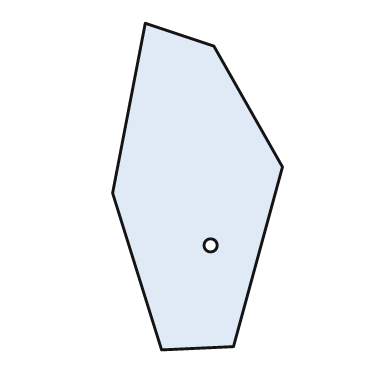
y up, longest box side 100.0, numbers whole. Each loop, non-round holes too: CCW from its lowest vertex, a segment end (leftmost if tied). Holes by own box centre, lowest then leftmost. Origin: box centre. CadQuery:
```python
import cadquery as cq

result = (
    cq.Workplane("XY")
    .moveTo(-11.0, -50.0)
    .lineTo(11.0, -49.0)
    .lineTo(26.0, 6.0)
    .lineTo(5.0, 43.0)
    .lineTo(-16.0, 50.0)
    .lineTo(-26.0, -2.0)
    .close()
    .moveTo(4.0, -18.0)
    .circle(2.0)
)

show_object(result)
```